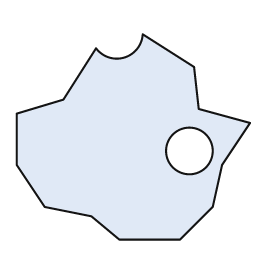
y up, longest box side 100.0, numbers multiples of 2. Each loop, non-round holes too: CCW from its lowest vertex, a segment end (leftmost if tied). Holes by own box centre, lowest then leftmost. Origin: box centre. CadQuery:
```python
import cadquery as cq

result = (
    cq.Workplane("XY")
    .moveTo(-6.0, -44.0)
    .lineTo(20.0, -44.0)
    .lineTo(34.0, -30.0)
    .lineTo(38.0, -12.0)
    .lineTo(50.0, 6.0)
    .lineTo(28.0, 12.0)
    .lineTo(26.0, 30.0)
    .lineTo(4.0, 44.0)
    .threePointArc((-4.0, 34.0), (-16.0, 38.0))
    .lineTo(-30.0, 16.0)
    .lineTo(-50.0, 10.0)
    .lineTo(-50.0, -12.0)
    .lineTo(-38.0, -30.0)
    .lineTo(-18.0, -34.0)
    .close()
    .moveTo(24.0, -6.0)
    .circle(10.0)
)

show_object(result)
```